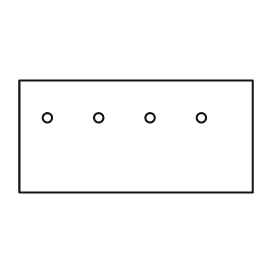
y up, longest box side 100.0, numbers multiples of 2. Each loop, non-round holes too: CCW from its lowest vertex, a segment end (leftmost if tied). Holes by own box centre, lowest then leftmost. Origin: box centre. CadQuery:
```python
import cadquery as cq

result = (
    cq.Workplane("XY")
    .moveTo(-50.0, -24.0)
    .lineTo(50.0, -24.0)
    .lineTo(50.0, 24.0)
    .lineTo(-50.0, 24.0)
    .close()
    .moveTo(-38.0, 8.0)
    .circle(2.0)
    .moveTo(-16.0, 8.0)
    .circle(2.0)
    .moveTo(6.0, 8.0)
    .circle(2.0)
    .moveTo(28.0, 8.0)
    .circle(2.0)
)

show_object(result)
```